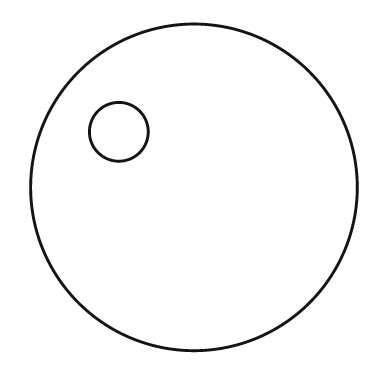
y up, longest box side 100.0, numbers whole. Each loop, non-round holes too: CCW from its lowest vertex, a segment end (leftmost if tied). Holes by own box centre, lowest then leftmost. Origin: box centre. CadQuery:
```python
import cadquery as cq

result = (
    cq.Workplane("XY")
    .moveTo(0.0, 0.0)
    .circle(50.0)
    .moveTo(-23.0, 17.0)
    .circle(9.0)
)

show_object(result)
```